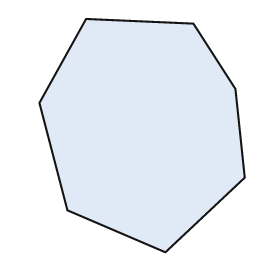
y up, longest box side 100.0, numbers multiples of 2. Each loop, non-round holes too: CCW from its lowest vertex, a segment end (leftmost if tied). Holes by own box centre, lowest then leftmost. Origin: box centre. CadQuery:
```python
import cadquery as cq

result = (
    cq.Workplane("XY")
    .moveTo(10.0, -50.0)
    .lineTo(44.0, -18.0)
    .lineTo(40.0, 20.0)
    .lineTo(22.0, 48.0)
    .lineTo(-24.0, 50.0)
    .lineTo(-44.0, 14.0)
    .lineTo(-32.0, -32.0)
    .close()
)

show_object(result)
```